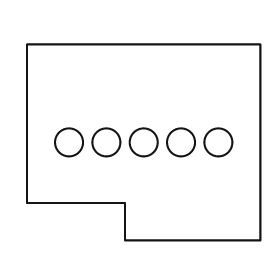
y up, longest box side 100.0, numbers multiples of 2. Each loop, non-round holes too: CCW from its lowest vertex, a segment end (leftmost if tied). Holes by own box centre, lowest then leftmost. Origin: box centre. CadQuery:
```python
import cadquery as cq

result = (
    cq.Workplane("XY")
    .moveTo(-8.0, -42.0)
    .lineTo(50.0, -42.0)
    .lineTo(50.0, 42.0)
    .lineTo(-50.0, 42.0)
    .lineTo(-50.0, -26.0)
    .lineTo(-8.0, -26.0)
    .close()
    .moveTo(-32.0, 0.0)
    .circle(6.0)
    .moveTo(-16.0, 0.0)
    .circle(6.0)
    .moveTo(0.0, 0.0)
    .circle(6.0)
    .moveTo(16.0, 0.0)
    .circle(6.0)
    .moveTo(32.0, 0.0)
    .circle(6.0)
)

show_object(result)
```